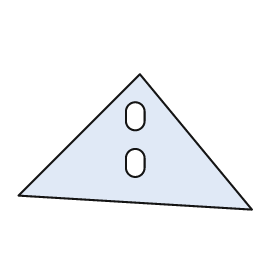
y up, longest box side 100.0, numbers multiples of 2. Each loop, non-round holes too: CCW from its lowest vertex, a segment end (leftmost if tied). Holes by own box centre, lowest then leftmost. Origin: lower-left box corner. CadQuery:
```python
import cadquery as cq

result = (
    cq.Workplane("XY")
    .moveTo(100.0, 0.0)
    .lineTo(52.0, 58.0)
    .lineTo(0.0, 6.0)
    .close()
    .moveTo(46.0, 18.0)
    .threePointArc((50.0, 14.0), (54.0, 18.0))
    .lineTo(54.0, 22.0)
    .threePointArc((50.0, 26.0), (46.0, 22.0))
    .close()
    .moveTo(46.0, 38.0)
    .threePointArc((50.0, 34.0), (54.0, 38.0))
    .lineTo(54.0, 42.0)
    .threePointArc((50.0, 46.0), (46.0, 42.0))
    .close()
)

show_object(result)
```